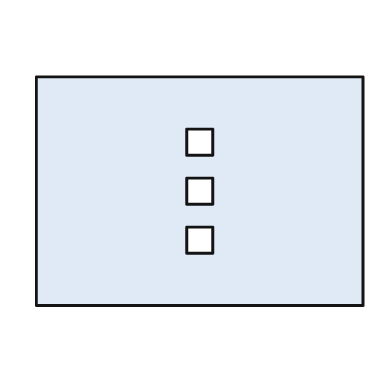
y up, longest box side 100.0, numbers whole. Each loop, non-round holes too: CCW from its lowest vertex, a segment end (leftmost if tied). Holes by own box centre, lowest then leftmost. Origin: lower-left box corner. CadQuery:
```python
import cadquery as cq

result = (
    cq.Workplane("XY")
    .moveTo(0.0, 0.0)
    .lineTo(100.0, 0.0)
    .lineTo(100.0, 70.0)
    .lineTo(0.0, 70.0)
    .close()
    .moveTo(46.0, 16.0)
    .lineTo(54.0, 16.0)
    .lineTo(54.0, 24.0)
    .lineTo(46.0, 24.0)
    .close()
    .moveTo(46.0, 31.0)
    .lineTo(54.0, 31.0)
    .lineTo(54.0, 39.0)
    .lineTo(46.0, 39.0)
    .close()
    .moveTo(46.0, 46.0)
    .lineTo(54.0, 46.0)
    .lineTo(54.0, 54.0)
    .lineTo(46.0, 54.0)
    .close()
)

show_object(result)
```